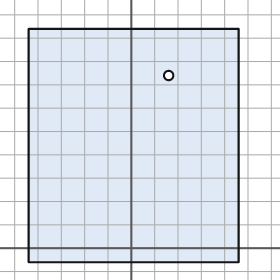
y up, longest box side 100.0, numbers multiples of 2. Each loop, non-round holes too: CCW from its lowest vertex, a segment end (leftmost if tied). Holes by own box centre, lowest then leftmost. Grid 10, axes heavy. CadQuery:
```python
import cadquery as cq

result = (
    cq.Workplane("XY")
    .moveTo(-44.0, -6.0)
    .lineTo(46.0, -6.0)
    .lineTo(46.0, 94.0)
    .lineTo(-44.0, 94.0)
    .close()
    .moveTo(16.0, 74.0)
    .circle(2.0)
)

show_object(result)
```